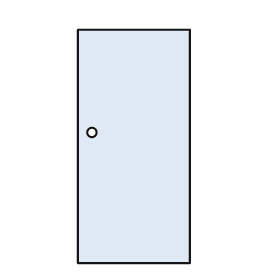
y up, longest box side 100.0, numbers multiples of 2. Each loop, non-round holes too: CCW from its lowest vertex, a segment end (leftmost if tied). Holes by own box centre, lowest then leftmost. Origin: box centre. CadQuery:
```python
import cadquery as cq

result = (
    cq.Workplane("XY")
    .moveTo(-24.0, -50.0)
    .lineTo(24.0, -50.0)
    .lineTo(24.0, 50.0)
    .lineTo(-24.0, 50.0)
    .close()
    .moveTo(-18.0, 6.0)
    .circle(2.0)
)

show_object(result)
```